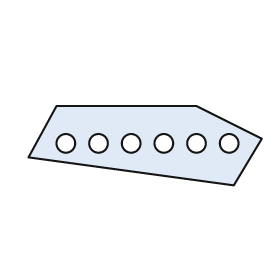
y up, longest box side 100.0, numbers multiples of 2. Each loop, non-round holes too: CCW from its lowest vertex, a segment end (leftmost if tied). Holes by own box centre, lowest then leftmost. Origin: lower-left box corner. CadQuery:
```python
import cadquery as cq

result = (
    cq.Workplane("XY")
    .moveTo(88.0, 0.0)
    .lineTo(100.0, 20.0)
    .lineTo(72.0, 34.0)
    .lineTo(12.0, 34.0)
    .lineTo(0.0, 12.0)
    .close()
    .moveTo(16.0, 18.0)
    .circle(4.0)
    .moveTo(30.0, 18.0)
    .circle(4.0)
    .moveTo(44.0, 18.0)
    .circle(4.0)
    .moveTo(58.0, 18.0)
    .circle(4.0)
    .moveTo(72.0, 18.0)
    .circle(4.0)
    .moveTo(86.0, 18.0)
    .circle(4.0)
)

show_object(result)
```